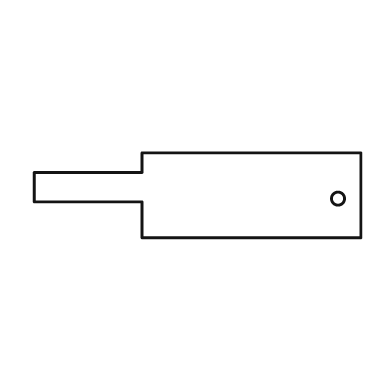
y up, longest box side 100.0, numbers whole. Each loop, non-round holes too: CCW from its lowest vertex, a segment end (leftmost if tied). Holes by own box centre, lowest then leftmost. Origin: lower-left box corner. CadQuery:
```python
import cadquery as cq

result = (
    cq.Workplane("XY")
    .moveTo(33.0, 0.0)
    .lineTo(100.0, 0.0)
    .lineTo(100.0, 26.0)
    .lineTo(33.0, 26.0)
    .lineTo(33.0, 20.0)
    .lineTo(0.0, 20.0)
    .lineTo(0.0, 11.0)
    .lineTo(33.0, 11.0)
    .close()
    .moveTo(93.0, 12.0)
    .circle(2.0)
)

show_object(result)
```